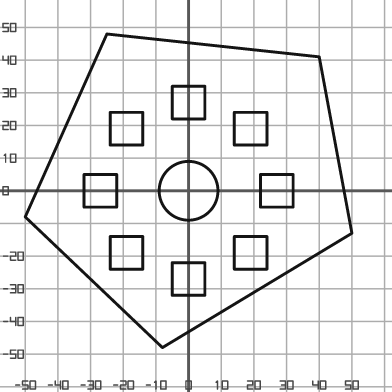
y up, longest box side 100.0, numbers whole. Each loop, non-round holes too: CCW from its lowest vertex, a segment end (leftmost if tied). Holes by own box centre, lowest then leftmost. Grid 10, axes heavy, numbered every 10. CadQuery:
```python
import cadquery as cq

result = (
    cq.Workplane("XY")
    .moveTo(-8.0, -48.0)
    .lineTo(50.0, -13.0)
    .lineTo(40.0, 41.0)
    .lineTo(-25.0, 48.0)
    .lineTo(-50.0, -8.0)
    .close()
    .moveTo(-5.0, -32.0)
    .lineTo(5.0, -32.0)
    .lineTo(5.0, -22.0)
    .lineTo(-5.0, -22.0)
    .close()
    .moveTo(-24.0, -24.0)
    .lineTo(-14.0, -24.0)
    .lineTo(-14.0, -14.0)
    .lineTo(-24.0, -14.0)
    .close()
    .moveTo(14.0, -24.0)
    .lineTo(24.0, -24.0)
    .lineTo(24.0, -14.0)
    .lineTo(14.0, -14.0)
    .close()
    .moveTo(-32.0, -5.0)
    .lineTo(-22.0, -5.0)
    .lineTo(-22.0, 5.0)
    .lineTo(-32.0, 5.0)
    .close()
    .moveTo(0.0, 0.0)
    .circle(9.0)
    .moveTo(22.0, -5.0)
    .lineTo(32.0, -5.0)
    .lineTo(32.0, 5.0)
    .lineTo(22.0, 5.0)
    .close()
    .moveTo(-24.0, 14.0)
    .lineTo(-14.0, 14.0)
    .lineTo(-14.0, 24.0)
    .lineTo(-24.0, 24.0)
    .close()
    .moveTo(14.0, 14.0)
    .lineTo(24.0, 14.0)
    .lineTo(24.0, 24.0)
    .lineTo(14.0, 24.0)
    .close()
    .moveTo(-5.0, 22.0)
    .lineTo(5.0, 22.0)
    .lineTo(5.0, 32.0)
    .lineTo(-5.0, 32.0)
    .close()
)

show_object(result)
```